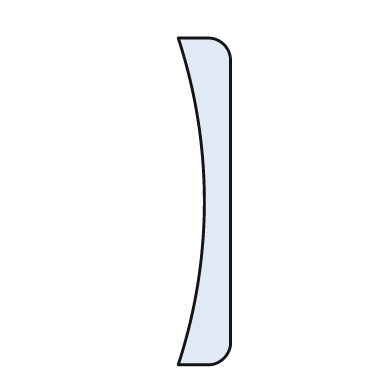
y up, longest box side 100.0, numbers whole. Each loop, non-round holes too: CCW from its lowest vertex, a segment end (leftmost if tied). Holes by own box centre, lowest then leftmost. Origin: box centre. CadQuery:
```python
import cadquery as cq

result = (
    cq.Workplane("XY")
    .moveTo(-8.0, -50.0)
    .lineTo(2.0, -50.0)
    .threePointArc((6.0, -48.0), (8.0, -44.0))
    .lineTo(8.0, 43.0)
    .threePointArc((6.0, 48.0), (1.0, 50.0))
    .lineTo(-8.0, 50.0)
    .threePointArc((0.0, 0.0), (-8.0, -50.0))
    .close()
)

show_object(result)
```